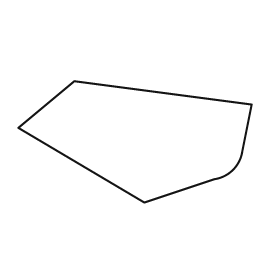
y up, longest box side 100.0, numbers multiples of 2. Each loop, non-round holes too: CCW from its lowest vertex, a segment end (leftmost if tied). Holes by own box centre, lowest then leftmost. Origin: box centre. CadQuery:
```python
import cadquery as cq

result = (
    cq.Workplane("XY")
    .moveTo(4.0, -26.0)
    .lineTo(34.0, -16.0)
    .threePointArc((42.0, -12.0), (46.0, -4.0))
    .lineTo(50.0, 16.0)
    .lineTo(-26.0, 26.0)
    .lineTo(-50.0, 6.0)
    .close()
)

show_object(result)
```